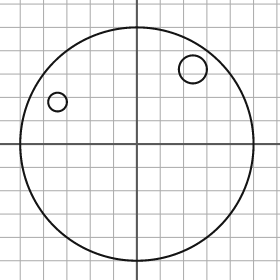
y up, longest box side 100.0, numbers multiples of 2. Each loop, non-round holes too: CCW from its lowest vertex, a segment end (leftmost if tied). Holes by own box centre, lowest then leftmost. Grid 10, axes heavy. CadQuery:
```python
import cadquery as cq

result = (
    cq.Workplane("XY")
    .moveTo(0.0, 0.0)
    .circle(50.0)
    .moveTo(-34.0, 18.0)
    .circle(4.0)
    .moveTo(24.0, 32.0)
    .circle(6.0)
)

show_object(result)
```